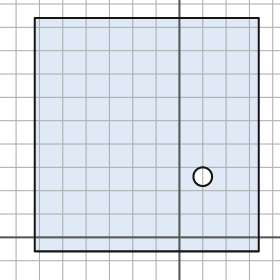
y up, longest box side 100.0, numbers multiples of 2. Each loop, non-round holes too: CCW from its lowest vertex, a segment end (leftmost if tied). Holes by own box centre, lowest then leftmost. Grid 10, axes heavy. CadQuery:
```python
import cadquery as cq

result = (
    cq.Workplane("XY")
    .moveTo(-62.0, -6.0)
    .lineTo(34.0, -6.0)
    .lineTo(34.0, 94.0)
    .lineTo(-62.0, 94.0)
    .close()
    .moveTo(10.0, 26.0)
    .circle(4.0)
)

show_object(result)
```